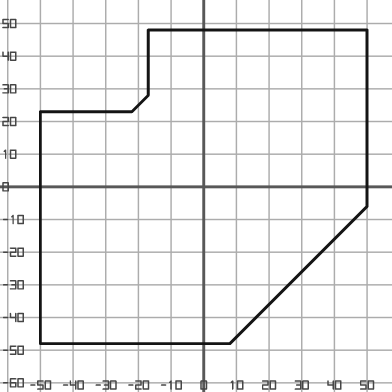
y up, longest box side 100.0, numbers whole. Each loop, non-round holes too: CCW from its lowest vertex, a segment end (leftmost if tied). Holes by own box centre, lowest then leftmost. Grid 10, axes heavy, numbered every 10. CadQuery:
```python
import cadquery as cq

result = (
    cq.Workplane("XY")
    .moveTo(-50.0, -48.0)
    .lineTo(8.0, -48.0)
    .lineTo(50.0, -6.0)
    .lineTo(50.0, 48.0)
    .lineTo(-17.0, 48.0)
    .lineTo(-17.0, 28.0)
    .lineTo(-22.0, 23.0)
    .lineTo(-50.0, 23.0)
    .close()
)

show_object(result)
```